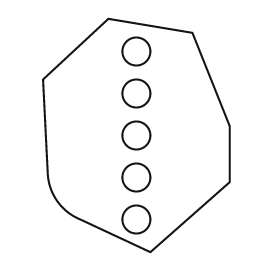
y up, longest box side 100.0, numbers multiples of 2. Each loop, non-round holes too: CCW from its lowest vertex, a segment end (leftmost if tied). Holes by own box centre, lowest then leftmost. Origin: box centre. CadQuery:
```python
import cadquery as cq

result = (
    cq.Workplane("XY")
    .moveTo(6.0, -50.0)
    .lineTo(40.0, -20.0)
    .lineTo(40.0, 4.0)
    .lineTo(24.0, 44.0)
    .lineTo(-12.0, 50.0)
    .lineTo(-40.0, 24.0)
    .lineTo(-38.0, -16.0)
    .threePointArc((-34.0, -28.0), (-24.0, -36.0))
    .close()
    .moveTo(0.0, -36.0)
    .circle(6.0)
    .moveTo(0.0, -18.0)
    .circle(6.0)
    .moveTo(0.0, 0.0)
    .circle(6.0)
    .moveTo(0.0, 18.0)
    .circle(6.0)
    .moveTo(0.0, 36.0)
    .circle(6.0)
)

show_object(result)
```